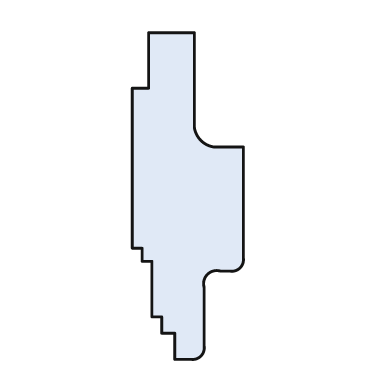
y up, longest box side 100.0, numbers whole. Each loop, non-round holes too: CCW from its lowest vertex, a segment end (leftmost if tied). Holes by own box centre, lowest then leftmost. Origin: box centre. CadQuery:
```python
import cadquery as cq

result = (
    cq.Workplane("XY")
    .moveTo(-4.0, -50.0)
    .lineTo(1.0, -50.0)
    .threePointArc((4.0, -49.0), (5.0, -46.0))
    .lineTo(5.0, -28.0)
    .threePointArc((6.0, -24.0), (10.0, -23.0))
    .lineTo(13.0, -23.0)
    .threePointArc((16.0, -22.0), (17.0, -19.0))
    .lineTo(17.0, 15.0)
    .lineTo(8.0, 15.0)
    .threePointArc((4.0, 17.0), (2.0, 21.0))
    .lineTo(2.0, 50.0)
    .lineTo(-12.0, 50.0)
    .lineTo(-12.0, 33.0)
    .lineTo(-17.0, 33.0)
    .lineTo(-17.0, -16.0)
    .lineTo(-14.0, -16.0)
    .lineTo(-14.0, -20.0)
    .lineTo(-11.0, -20.0)
    .lineTo(-11.0, -37.0)
    .lineTo(-8.0, -37.0)
    .lineTo(-8.0, -42.0)
    .lineTo(-4.0, -42.0)
    .close()
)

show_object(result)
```